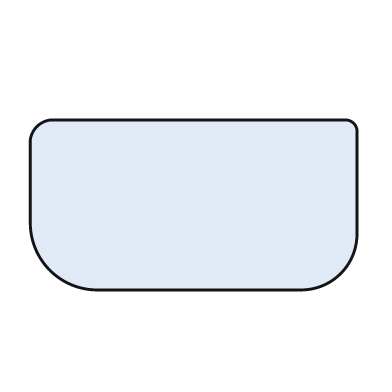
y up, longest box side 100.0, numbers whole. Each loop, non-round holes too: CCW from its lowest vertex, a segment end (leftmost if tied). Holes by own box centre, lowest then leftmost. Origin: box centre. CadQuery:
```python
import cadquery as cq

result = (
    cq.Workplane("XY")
    .moveTo(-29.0, -26.0)
    .lineTo(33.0, -26.0)
    .threePointArc((45.0, -21.0), (50.0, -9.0))
    .lineTo(50.0, 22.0)
    .threePointArc((49.0, 25.0), (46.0, 26.0))
    .lineTo(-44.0, 26.0)
    .threePointArc((-48.0, 24.0), (-50.0, 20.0))
    .lineTo(-50.0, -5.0)
    .threePointArc((-44.0, -20.0), (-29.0, -26.0))
    .close()
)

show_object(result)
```